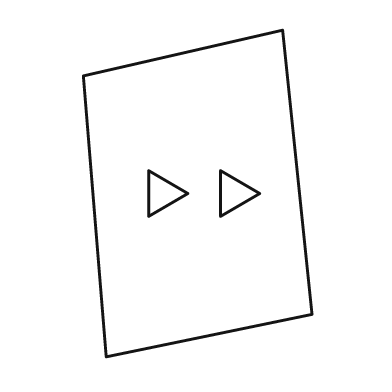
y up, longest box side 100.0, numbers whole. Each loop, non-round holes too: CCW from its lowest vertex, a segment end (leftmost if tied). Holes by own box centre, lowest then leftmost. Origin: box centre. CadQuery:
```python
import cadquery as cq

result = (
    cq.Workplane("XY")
    .moveTo(-28.0, -50.0)
    .lineTo(35.0, -37.0)
    .lineTo(26.0, 50.0)
    .lineTo(-35.0, 36.0)
    .close()
    .moveTo(-15.0, -7.0)
    .lineTo(-3.0, 0.0)
    .lineTo(-15.0, 7.0)
    .close()
    .moveTo(7.0, -7.0)
    .lineTo(19.0, 0.0)
    .lineTo(7.0, 7.0)
    .close()
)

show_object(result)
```